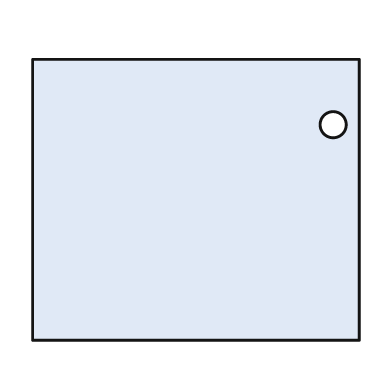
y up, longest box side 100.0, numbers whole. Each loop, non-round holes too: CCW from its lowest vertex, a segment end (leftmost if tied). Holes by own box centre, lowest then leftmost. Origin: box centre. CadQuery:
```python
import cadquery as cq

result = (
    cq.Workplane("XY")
    .moveTo(-50.0, -43.0)
    .lineTo(50.0, -43.0)
    .lineTo(50.0, 43.0)
    .lineTo(-50.0, 43.0)
    .close()
    .moveTo(42.0, 23.0)
    .circle(4.0)
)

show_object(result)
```